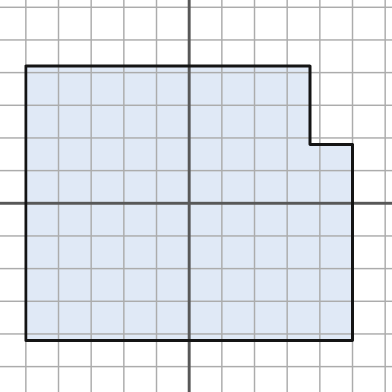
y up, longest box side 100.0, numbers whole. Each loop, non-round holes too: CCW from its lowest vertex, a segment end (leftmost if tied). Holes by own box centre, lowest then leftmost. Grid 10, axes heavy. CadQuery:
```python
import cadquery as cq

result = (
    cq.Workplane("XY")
    .moveTo(-50.0, -42.0)
    .lineTo(50.0, -42.0)
    .lineTo(50.0, 18.0)
    .lineTo(37.0, 18.0)
    .lineTo(37.0, 42.0)
    .lineTo(-50.0, 42.0)
    .close()
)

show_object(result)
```